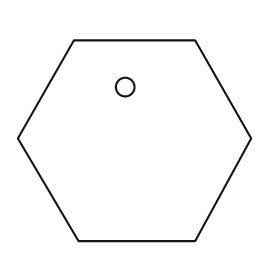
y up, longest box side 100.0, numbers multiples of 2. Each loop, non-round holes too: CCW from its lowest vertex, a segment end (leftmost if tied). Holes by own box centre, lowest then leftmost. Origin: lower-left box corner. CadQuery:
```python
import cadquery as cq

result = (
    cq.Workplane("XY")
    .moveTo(26.0, 0.0)
    .lineTo(76.0, 0.0)
    .lineTo(100.0, 44.0)
    .lineTo(76.0, 86.0)
    .lineTo(24.0, 86.0)
    .lineTo(0.0, 44.0)
    .close()
    .moveTo(46.0, 66.0)
    .circle(4.0)
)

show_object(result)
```